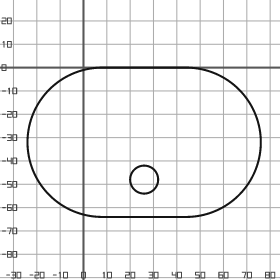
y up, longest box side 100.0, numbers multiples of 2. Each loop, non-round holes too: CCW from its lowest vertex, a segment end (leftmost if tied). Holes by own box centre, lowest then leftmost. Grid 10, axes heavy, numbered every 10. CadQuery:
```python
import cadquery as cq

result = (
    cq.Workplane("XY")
    .moveTo(8.0, -64.0)
    .lineTo(44.0, -64.0)
    .threePointArc((76.0, -32.0), (44.0, 0.0))
    .lineTo(8.0, 0.0)
    .threePointArc((-24.0, -32.0), (8.0, -64.0))
    .close()
    .moveTo(26.0, -48.0)
    .circle(6.0)
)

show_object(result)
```